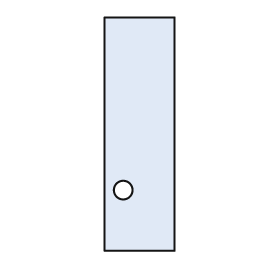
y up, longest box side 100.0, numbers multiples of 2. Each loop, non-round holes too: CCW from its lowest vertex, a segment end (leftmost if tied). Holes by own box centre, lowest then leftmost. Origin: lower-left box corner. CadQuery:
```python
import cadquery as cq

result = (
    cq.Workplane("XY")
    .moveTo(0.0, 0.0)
    .lineTo(30.0, 0.0)
    .lineTo(30.0, 100.0)
    .lineTo(0.0, 100.0)
    .close()
    .moveTo(8.0, 26.0)
    .circle(4.0)
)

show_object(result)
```